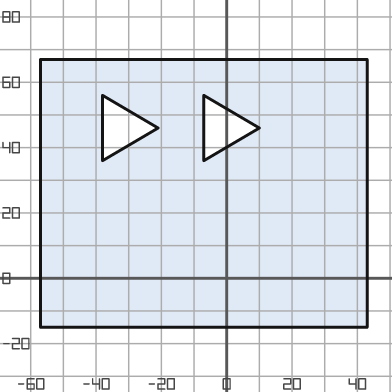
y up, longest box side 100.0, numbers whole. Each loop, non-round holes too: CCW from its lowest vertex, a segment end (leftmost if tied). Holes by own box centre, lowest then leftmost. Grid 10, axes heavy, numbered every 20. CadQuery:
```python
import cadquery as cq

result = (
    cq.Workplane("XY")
    .moveTo(-57.0, -15.0)
    .lineTo(43.0, -15.0)
    .lineTo(43.0, 67.0)
    .lineTo(-57.0, 67.0)
    .close()
    .moveTo(-38.0, 36.0)
    .lineTo(-21.0, 46.0)
    .lineTo(-38.0, 56.0)
    .close()
    .moveTo(-7.0, 36.0)
    .lineTo(10.0, 46.0)
    .lineTo(-7.0, 56.0)
    .close()
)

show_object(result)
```